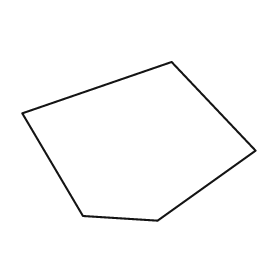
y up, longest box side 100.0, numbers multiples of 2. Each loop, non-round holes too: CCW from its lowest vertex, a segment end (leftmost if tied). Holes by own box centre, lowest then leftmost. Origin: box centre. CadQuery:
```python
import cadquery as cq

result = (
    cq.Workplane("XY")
    .moveTo(8.0, -34.0)
    .lineTo(50.0, -4.0)
    .lineTo(14.0, 34.0)
    .lineTo(-50.0, 12.0)
    .lineTo(-24.0, -32.0)
    .close()
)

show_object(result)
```